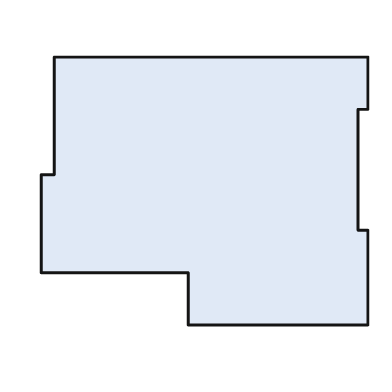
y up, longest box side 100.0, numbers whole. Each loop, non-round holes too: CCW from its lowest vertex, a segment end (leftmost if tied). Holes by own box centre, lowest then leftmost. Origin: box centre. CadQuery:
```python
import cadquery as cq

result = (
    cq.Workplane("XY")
    .moveTo(-5.0, -41.0)
    .lineTo(50.0, -41.0)
    .lineTo(50.0, -12.0)
    .lineTo(47.0, -12.0)
    .lineTo(47.0, 25.0)
    .lineTo(50.0, 25.0)
    .lineTo(50.0, 41.0)
    .lineTo(-46.0, 41.0)
    .lineTo(-46.0, 5.0)
    .lineTo(-50.0, 5.0)
    .lineTo(-50.0, -25.0)
    .lineTo(-5.0, -25.0)
    .close()
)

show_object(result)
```